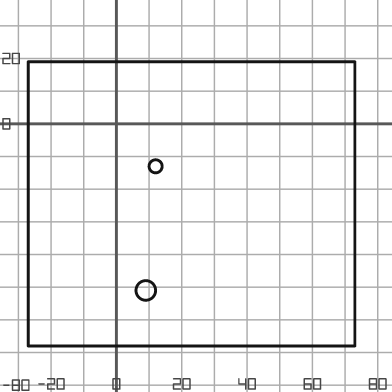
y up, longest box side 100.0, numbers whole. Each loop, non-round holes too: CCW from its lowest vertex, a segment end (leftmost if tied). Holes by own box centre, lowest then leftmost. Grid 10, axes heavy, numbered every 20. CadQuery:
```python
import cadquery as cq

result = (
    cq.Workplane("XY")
    .moveTo(-27.0, -68.0)
    .lineTo(73.0, -68.0)
    .lineTo(73.0, 19.0)
    .lineTo(-27.0, 19.0)
    .close()
    .moveTo(9.0, -51.0)
    .circle(3.0)
    .moveTo(12.0, -13.0)
    .circle(2.0)
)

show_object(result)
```